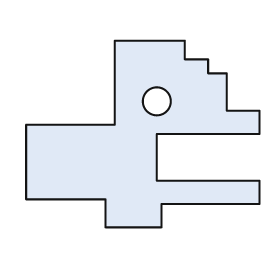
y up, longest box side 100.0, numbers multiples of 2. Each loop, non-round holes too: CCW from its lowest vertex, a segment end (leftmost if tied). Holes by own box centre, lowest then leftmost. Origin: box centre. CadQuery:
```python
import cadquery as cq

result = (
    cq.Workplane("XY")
    .moveTo(-16.0, -40.0)
    .lineTo(8.0, -40.0)
    .lineTo(8.0, -30.0)
    .lineTo(50.0, -30.0)
    .lineTo(50.0, -20.0)
    .lineTo(6.0, -20.0)
    .lineTo(6.0, 0.0)
    .lineTo(50.0, 0.0)
    .lineTo(50.0, 10.0)
    .lineTo(36.0, 10.0)
    .lineTo(36.0, 26.0)
    .lineTo(28.0, 26.0)
    .lineTo(28.0, 32.0)
    .lineTo(18.0, 32.0)
    .lineTo(18.0, 40.0)
    .lineTo(-12.0, 40.0)
    .lineTo(-12.0, 4.0)
    .lineTo(-50.0, 4.0)
    .lineTo(-50.0, -28.0)
    .lineTo(-16.0, -28.0)
    .close()
    .moveTo(6.0, 14.0)
    .circle(6.0)
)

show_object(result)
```